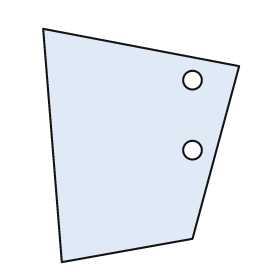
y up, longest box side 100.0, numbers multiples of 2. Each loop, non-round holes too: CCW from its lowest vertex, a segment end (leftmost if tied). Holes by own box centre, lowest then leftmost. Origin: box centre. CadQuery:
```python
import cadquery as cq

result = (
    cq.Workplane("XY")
    .moveTo(-34.0, -50.0)
    .lineTo(22.0, -40.0)
    .lineTo(42.0, 34.0)
    .lineTo(-42.0, 50.0)
    .close()
    .moveTo(22.0, -2.0)
    .circle(4.0)
    .moveTo(22.0, 28.0)
    .circle(4.0)
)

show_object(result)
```